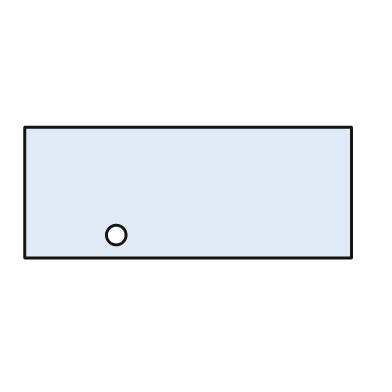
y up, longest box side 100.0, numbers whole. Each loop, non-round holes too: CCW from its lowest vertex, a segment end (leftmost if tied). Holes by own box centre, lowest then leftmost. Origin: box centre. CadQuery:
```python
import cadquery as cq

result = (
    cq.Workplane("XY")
    .moveTo(-50.0, -20.0)
    .lineTo(50.0, -20.0)
    .lineTo(50.0, 20.0)
    .lineTo(-50.0, 20.0)
    .close()
    .moveTo(-22.0, -13.0)
    .circle(3.0)
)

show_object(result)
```